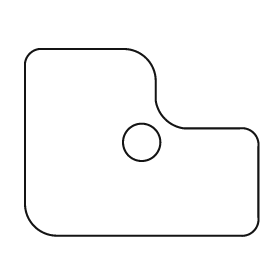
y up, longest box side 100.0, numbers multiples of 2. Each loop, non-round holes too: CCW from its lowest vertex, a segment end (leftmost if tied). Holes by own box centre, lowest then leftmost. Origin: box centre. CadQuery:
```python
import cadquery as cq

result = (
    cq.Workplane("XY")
    .moveTo(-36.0, -40.0)
    .lineTo(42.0, -40.0)
    .threePointArc((48.0, -38.0), (50.0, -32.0))
    .lineTo(50.0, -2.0)
    .threePointArc((48.0, 4.0), (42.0, 6.0))
    .lineTo(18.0, 6.0)
    .threePointArc((10.0, 10.0), (6.0, 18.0))
    .lineTo(6.0, 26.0)
    .threePointArc((2.0, 36.0), (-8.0, 40.0))
    .lineTo(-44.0, 40.0)
    .threePointArc((-48.0, 38.0), (-50.0, 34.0))
    .lineTo(-50.0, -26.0)
    .threePointArc((-46.0, -36.0), (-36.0, -40.0))
    .close()
    .moveTo(0.0, 0.0)
    .circle(8.0)
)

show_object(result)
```